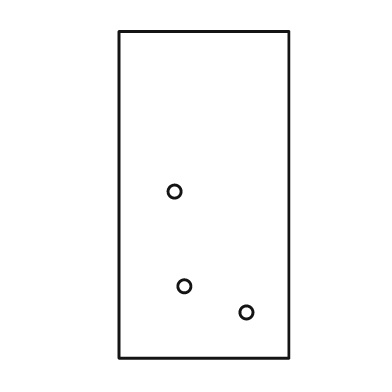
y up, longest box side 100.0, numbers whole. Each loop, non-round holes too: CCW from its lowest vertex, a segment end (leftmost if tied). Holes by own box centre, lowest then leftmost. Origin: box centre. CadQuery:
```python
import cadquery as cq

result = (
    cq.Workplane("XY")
    .moveTo(-26.0, -50.0)
    .lineTo(26.0, -50.0)
    .lineTo(26.0, 50.0)
    .lineTo(-26.0, 50.0)
    .close()
    .moveTo(13.0, -36.0)
    .circle(2.0)
    .moveTo(-6.0, -28.0)
    .circle(2.0)
    .moveTo(-9.0, 1.0)
    .circle(2.0)
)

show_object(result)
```